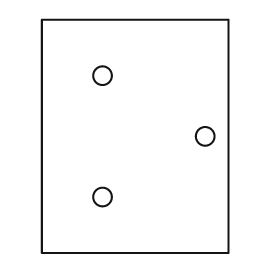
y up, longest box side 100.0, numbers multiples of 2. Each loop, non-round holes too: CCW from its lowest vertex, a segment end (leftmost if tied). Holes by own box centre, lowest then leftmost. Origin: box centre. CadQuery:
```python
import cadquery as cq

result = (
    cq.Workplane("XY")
    .moveTo(-40.0, -50.0)
    .lineTo(40.0, -50.0)
    .lineTo(40.0, 50.0)
    .lineTo(-40.0, 50.0)
    .close()
    .moveTo(-14.0, -26.0)
    .circle(4.0)
    .moveTo(30.0, 0.0)
    .circle(4.0)
    .moveTo(-14.0, 26.0)
    .circle(4.0)
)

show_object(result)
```